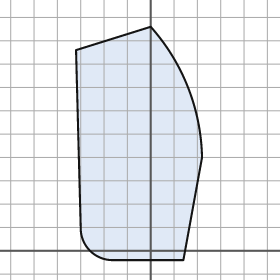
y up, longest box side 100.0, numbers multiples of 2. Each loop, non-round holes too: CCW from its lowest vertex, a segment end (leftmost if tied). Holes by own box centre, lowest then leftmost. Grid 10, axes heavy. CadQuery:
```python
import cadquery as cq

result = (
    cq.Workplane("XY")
    .moveTo(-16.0, -4.0)
    .lineTo(14.0, -4.0)
    .lineTo(22.0, 40.0)
    .threePointArc((16.0, 70.0), (0.0, 96.0))
    .lineTo(-32.0, 86.0)
    .lineTo(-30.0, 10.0)
    .threePointArc((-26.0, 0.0), (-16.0, -4.0))
    .close()
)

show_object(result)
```